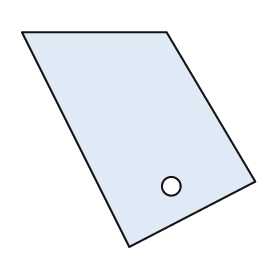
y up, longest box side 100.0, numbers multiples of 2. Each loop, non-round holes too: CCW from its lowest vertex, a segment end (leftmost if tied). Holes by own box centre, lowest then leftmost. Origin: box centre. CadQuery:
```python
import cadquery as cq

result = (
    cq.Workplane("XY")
    .moveTo(-4.0, -46.0)
    .lineTo(50.0, -18.0)
    .lineTo(12.0, 46.0)
    .lineTo(-50.0, 46.0)
    .close()
    .moveTo(14.0, -20.0)
    .circle(4.0)
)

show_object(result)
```